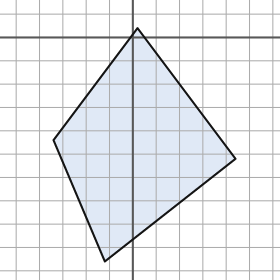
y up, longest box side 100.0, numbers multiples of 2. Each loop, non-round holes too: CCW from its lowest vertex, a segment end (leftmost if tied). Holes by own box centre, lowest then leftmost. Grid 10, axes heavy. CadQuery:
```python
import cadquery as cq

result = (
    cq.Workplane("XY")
    .moveTo(-12.0, -96.0)
    .lineTo(44.0, -52.0)
    .lineTo(2.0, 4.0)
    .lineTo(-34.0, -44.0)
    .close()
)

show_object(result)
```